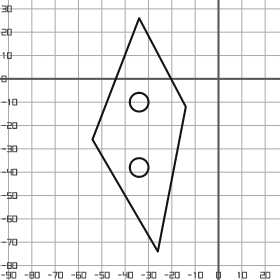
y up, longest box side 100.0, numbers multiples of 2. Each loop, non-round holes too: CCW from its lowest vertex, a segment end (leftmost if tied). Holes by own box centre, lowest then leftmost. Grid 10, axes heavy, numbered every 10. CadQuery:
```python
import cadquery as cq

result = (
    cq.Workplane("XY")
    .moveTo(-26.0, -74.0)
    .lineTo(-14.0, -12.0)
    .lineTo(-34.0, 26.0)
    .lineTo(-54.0, -26.0)
    .close()
    .moveTo(-34.0, -38.0)
    .circle(4.0)
    .moveTo(-34.0, -10.0)
    .circle(4.0)
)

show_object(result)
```